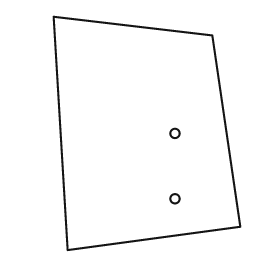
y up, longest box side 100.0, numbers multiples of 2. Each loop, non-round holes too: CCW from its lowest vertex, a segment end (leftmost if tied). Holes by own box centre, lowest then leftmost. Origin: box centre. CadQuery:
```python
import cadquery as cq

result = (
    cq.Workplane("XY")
    .moveTo(-34.0, -50.0)
    .lineTo(40.0, -40.0)
    .lineTo(28.0, 42.0)
    .lineTo(-40.0, 50.0)
    .close()
    .moveTo(12.0, -28.0)
    .circle(2.0)
    .moveTo(12.0, 0.0)
    .circle(2.0)
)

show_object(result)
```